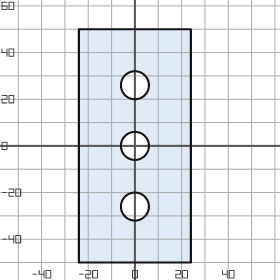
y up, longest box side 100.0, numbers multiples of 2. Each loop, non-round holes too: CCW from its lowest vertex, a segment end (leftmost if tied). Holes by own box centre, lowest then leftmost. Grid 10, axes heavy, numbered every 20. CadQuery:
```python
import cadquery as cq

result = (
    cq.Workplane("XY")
    .moveTo(-24.0, -50.0)
    .lineTo(24.0, -50.0)
    .lineTo(24.0, 50.0)
    .lineTo(-24.0, 50.0)
    .close()
    .moveTo(0.0, -26.0)
    .circle(6.0)
    .moveTo(0.0, 0.0)
    .circle(6.0)
    .moveTo(0.0, 26.0)
    .circle(6.0)
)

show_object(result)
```